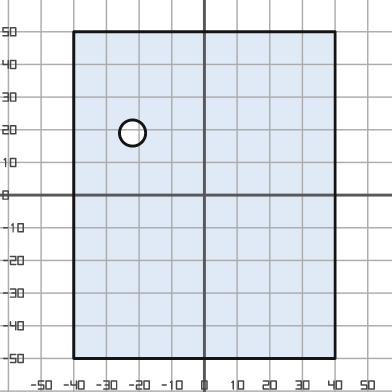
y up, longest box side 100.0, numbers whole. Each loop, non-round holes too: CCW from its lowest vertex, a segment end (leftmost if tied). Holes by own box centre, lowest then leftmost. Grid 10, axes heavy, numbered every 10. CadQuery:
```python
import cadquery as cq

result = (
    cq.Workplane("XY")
    .moveTo(-40.0, -50.0)
    .lineTo(40.0, -50.0)
    .lineTo(40.0, 50.0)
    .lineTo(-40.0, 50.0)
    .close()
    .moveTo(-22.0, 19.0)
    .circle(4.0)
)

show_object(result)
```